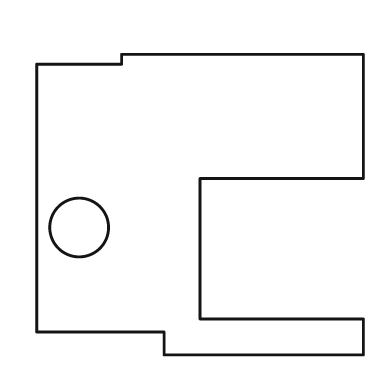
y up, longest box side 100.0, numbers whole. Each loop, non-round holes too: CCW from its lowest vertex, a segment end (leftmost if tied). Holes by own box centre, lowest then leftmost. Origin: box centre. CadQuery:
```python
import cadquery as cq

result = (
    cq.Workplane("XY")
    .moveTo(-11.0, -46.0)
    .lineTo(50.0, -46.0)
    .lineTo(50.0, -35.0)
    .lineTo(0.0, -35.0)
    .lineTo(0.0, 8.0)
    .lineTo(50.0, 8.0)
    .lineTo(50.0, 46.0)
    .lineTo(-24.0, 46.0)
    .lineTo(-24.0, 43.0)
    .lineTo(-50.0, 43.0)
    .lineTo(-50.0, -39.0)
    .lineTo(-11.0, -39.0)
    .close()
    .moveTo(-37.0, -7.0)
    .circle(9.0)
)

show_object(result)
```